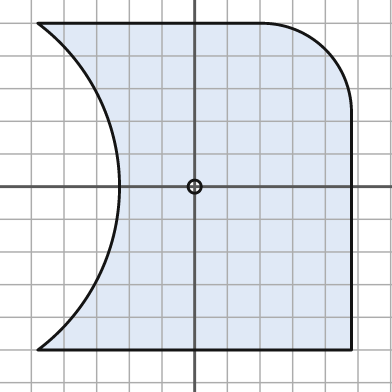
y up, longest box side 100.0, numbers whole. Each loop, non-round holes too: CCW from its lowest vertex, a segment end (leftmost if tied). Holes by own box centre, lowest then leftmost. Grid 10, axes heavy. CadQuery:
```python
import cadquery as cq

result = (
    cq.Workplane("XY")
    .moveTo(-48.0, -50.0)
    .lineTo(48.0, -50.0)
    .lineTo(48.0, 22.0)
    .threePointArc((40.0, 42.0), (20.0, 50.0))
    .lineTo(-48.0, 50.0)
    .threePointArc((-23.0, 0.0), (-48.0, -50.0))
    .close()
    .moveTo(0.0, 0.0)
    .circle(2.0)
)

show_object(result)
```